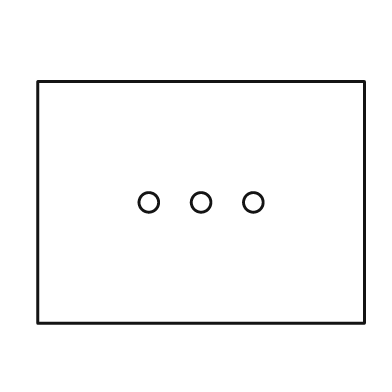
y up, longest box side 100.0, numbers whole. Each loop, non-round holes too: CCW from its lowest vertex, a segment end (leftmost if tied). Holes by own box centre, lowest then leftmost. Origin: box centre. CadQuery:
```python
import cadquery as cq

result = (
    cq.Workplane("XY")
    .moveTo(-50.0, -37.0)
    .lineTo(50.0, -37.0)
    .lineTo(50.0, 37.0)
    .lineTo(-50.0, 37.0)
    .close()
    .moveTo(-16.0, 0.0)
    .circle(3.0)
    .moveTo(0.0, 0.0)
    .circle(3.0)
    .moveTo(16.0, 0.0)
    .circle(3.0)
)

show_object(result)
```